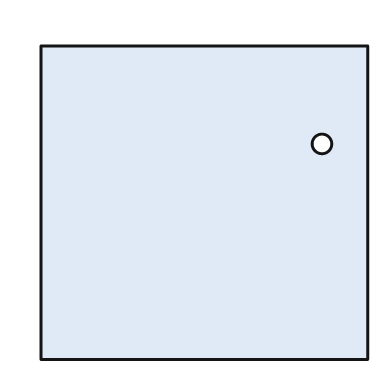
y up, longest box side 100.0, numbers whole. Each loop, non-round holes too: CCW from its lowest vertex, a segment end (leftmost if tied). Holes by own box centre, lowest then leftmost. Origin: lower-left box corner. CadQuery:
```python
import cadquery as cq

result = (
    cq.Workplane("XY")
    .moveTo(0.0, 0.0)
    .lineTo(100.0, 0.0)
    .lineTo(100.0, 96.0)
    .lineTo(0.0, 96.0)
    .close()
    .moveTo(86.0, 66.0)
    .circle(3.0)
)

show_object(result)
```